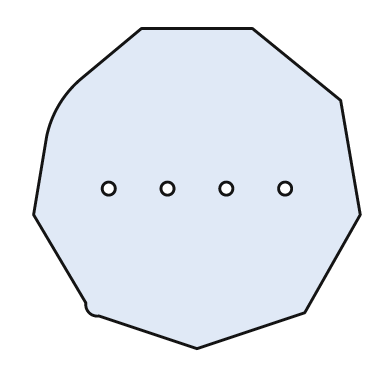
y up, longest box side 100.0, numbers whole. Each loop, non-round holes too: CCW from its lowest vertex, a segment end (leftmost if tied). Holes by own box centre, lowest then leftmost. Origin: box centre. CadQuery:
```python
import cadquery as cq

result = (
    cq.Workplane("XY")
    .moveTo(0.0, -49.0)
    .lineTo(33.0, -38.0)
    .lineTo(50.0, -8.0)
    .lineTo(44.0, 27.0)
    .lineTo(17.0, 49.0)
    .lineTo(-17.0, 49.0)
    .lineTo(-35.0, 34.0)
    .threePointArc((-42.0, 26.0), (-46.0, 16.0))
    .lineTo(-50.0, -8.0)
    .lineTo(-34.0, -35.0)
    .threePointArc((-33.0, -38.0), (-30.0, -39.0))
    .close()
    .moveTo(-27.0, 0.0)
    .circle(2.0)
    .moveTo(-9.0, 0.0)
    .circle(2.0)
    .moveTo(9.0, 0.0)
    .circle(2.0)
    .moveTo(27.0, 0.0)
    .circle(2.0)
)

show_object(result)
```